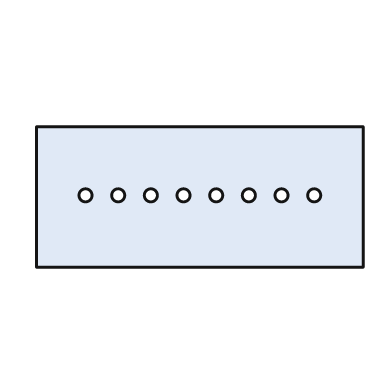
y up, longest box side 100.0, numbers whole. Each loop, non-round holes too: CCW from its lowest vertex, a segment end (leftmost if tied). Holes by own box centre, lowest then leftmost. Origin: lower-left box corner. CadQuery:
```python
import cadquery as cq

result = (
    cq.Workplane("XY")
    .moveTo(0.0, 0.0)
    .lineTo(100.0, 0.0)
    .lineTo(100.0, 43.0)
    .lineTo(0.0, 43.0)
    .close()
    .moveTo(15.0, 22.0)
    .circle(2.0)
    .moveTo(25.0, 22.0)
    .circle(2.0)
    .moveTo(35.0, 22.0)
    .circle(2.0)
    .moveTo(45.0, 22.0)
    .circle(2.0)
    .moveTo(55.0, 22.0)
    .circle(2.0)
    .moveTo(65.0, 22.0)
    .circle(2.0)
    .moveTo(75.0, 22.0)
    .circle(2.0)
    .moveTo(85.0, 22.0)
    .circle(2.0)
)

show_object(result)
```